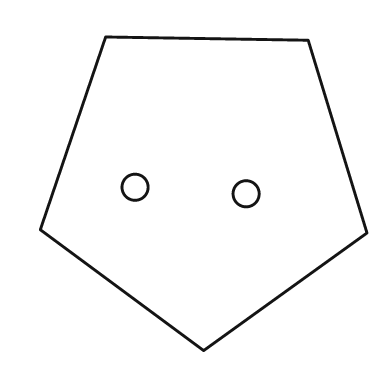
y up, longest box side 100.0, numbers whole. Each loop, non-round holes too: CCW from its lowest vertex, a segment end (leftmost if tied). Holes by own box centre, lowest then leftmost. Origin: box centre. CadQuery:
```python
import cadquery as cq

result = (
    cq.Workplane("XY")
    .moveTo(0.0, -48.0)
    .lineTo(50.0, -12.0)
    .lineTo(32.0, 47.0)
    .lineTo(-30.0, 48.0)
    .lineTo(-50.0, -11.0)
    .close()
    .moveTo(13.0, 0.0)
    .circle(4.0)
    .moveTo(-21.0, 2.0)
    .circle(4.0)
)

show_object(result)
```